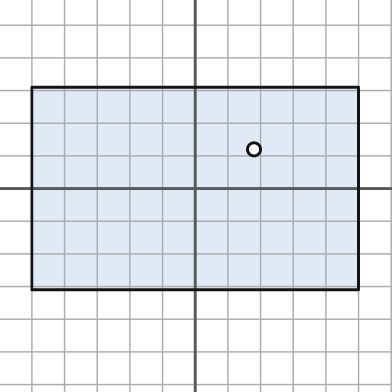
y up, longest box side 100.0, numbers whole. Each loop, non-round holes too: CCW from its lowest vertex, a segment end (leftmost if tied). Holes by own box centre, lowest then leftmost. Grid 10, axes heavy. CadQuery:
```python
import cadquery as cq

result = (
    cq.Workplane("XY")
    .moveTo(-50.0, -31.0)
    .lineTo(50.0, -31.0)
    .lineTo(50.0, 31.0)
    .lineTo(-50.0, 31.0)
    .close()
    .moveTo(18.0, 12.0)
    .circle(2.0)
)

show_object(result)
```